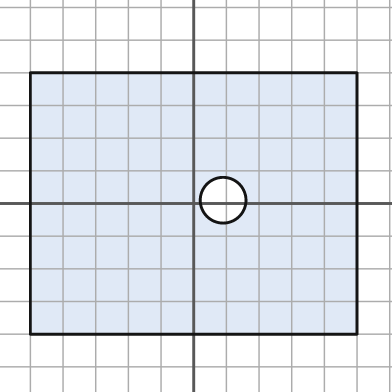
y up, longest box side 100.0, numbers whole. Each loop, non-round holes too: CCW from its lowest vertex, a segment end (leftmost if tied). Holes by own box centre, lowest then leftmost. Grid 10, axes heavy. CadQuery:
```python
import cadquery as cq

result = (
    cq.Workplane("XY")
    .moveTo(-50.0, -40.0)
    .lineTo(50.0, -40.0)
    .lineTo(50.0, 40.0)
    .lineTo(-50.0, 40.0)
    .close()
    .moveTo(9.0, 1.0)
    .circle(7.0)
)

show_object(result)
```